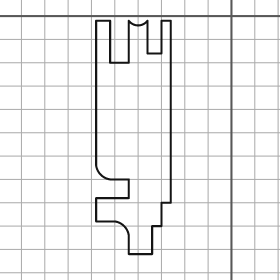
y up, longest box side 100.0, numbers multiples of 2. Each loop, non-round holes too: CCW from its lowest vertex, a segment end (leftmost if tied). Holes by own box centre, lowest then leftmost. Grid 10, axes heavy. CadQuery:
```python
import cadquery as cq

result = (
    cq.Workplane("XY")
    .moveTo(-44.0, -102.0)
    .lineTo(-34.0, -102.0)
    .lineTo(-34.0, -90.0)
    .lineTo(-30.0, -90.0)
    .lineTo(-30.0, -80.0)
    .lineTo(-26.0, -80.0)
    .lineTo(-26.0, -2.0)
    .lineTo(-30.0, -2.0)
    .lineTo(-30.0, -16.0)
    .lineTo(-36.0, -16.0)
    .lineTo(-36.0, -2.0)
    .threePointArc((-40.0, -4.0), (-44.0, -2.0))
    .lineTo(-44.0, -20.0)
    .lineTo(-52.0, -20.0)
    .lineTo(-52.0, -2.0)
    .lineTo(-58.0, -2.0)
    .lineTo(-58.0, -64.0)
    .threePointArc((-56.0, -68.0), (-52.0, -70.0))
    .lineTo(-44.0, -70.0)
    .lineTo(-44.0, -78.0)
    .lineTo(-58.0, -78.0)
    .lineTo(-58.0, -88.0)
    .lineTo(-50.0, -88.0)
    .threePointArc((-46.0, -90.0), (-44.0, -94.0))
    .close()
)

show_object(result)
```